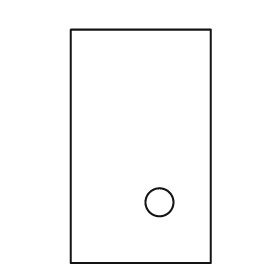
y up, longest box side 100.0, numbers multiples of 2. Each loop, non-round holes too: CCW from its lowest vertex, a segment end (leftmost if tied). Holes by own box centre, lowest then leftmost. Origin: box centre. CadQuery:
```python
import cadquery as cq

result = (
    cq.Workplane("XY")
    .moveTo(-30.0, -50.0)
    .lineTo(30.0, -50.0)
    .lineTo(30.0, 50.0)
    .lineTo(-30.0, 50.0)
    .close()
    .moveTo(8.0, -24.0)
    .circle(6.0)
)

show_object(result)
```